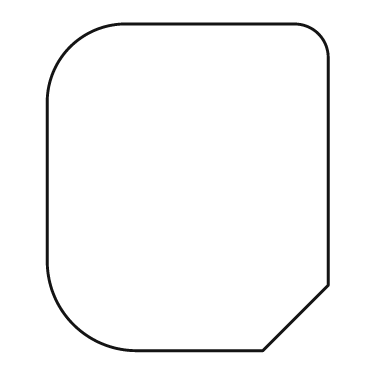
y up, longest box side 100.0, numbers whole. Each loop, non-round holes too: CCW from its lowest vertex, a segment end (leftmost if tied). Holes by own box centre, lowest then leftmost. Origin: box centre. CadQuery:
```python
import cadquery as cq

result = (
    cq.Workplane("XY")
    .moveTo(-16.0, -50.0)
    .lineTo(23.0, -50.0)
    .lineTo(43.0, -30.0)
    .lineTo(43.0, 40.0)
    .threePointArc((40.0, 47.0), (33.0, 50.0))
    .lineTo(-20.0, 50.0)
    .threePointArc((-36.0, 43.0), (-43.0, 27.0))
    .lineTo(-43.0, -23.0)
    .threePointArc((-35.0, -42.0), (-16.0, -50.0))
    .close()
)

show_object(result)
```